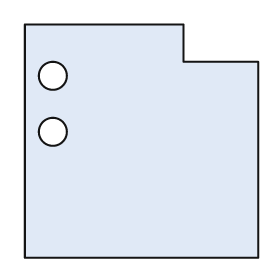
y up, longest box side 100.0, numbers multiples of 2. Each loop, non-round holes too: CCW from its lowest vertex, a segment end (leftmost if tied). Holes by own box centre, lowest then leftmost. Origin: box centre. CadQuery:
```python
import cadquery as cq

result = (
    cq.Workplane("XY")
    .moveTo(-50.0, -50.0)
    .lineTo(50.0, -50.0)
    .lineTo(50.0, 34.0)
    .lineTo(18.0, 34.0)
    .lineTo(18.0, 50.0)
    .lineTo(-50.0, 50.0)
    .close()
    .moveTo(-38.0, 4.0)
    .circle(6.0)
    .moveTo(-38.0, 28.0)
    .circle(6.0)
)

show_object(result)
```